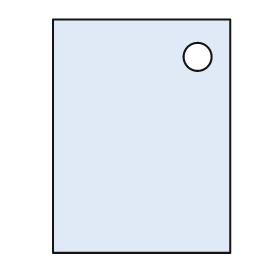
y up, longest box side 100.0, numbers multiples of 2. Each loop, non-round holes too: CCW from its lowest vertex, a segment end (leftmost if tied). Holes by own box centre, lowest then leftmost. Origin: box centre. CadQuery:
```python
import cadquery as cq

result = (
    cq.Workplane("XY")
    .moveTo(-38.0, -50.0)
    .lineTo(38.0, -50.0)
    .lineTo(38.0, 50.0)
    .lineTo(-38.0, 50.0)
    .close()
    .moveTo(24.0, 34.0)
    .circle(6.0)
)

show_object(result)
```